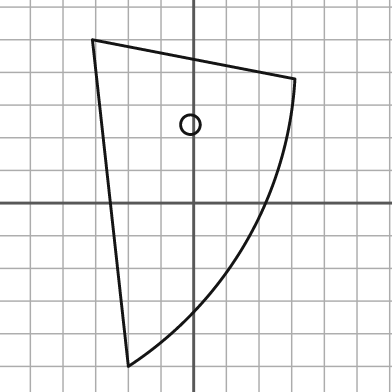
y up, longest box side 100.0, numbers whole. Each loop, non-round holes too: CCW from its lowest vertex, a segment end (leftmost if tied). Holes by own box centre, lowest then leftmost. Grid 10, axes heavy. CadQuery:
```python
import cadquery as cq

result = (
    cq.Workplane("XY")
    .moveTo(-20.0, -50.0)
    .threePointArc((16.0, -12.0), (31.0, 38.0))
    .lineTo(-31.0, 50.0)
    .close()
    .moveTo(-1.0, 24.0)
    .circle(3.0)
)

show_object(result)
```